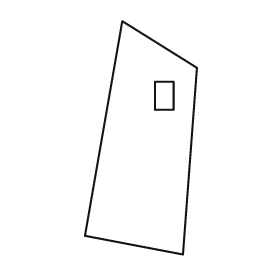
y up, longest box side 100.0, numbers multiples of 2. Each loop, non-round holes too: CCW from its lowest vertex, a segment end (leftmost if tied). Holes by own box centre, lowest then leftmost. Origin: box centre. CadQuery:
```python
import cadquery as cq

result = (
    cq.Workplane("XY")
    .moveTo(18.0, -50.0)
    .lineTo(24.0, 30.0)
    .lineTo(-8.0, 50.0)
    .lineTo(-24.0, -42.0)
    .close()
    .moveTo(6.0, 12.0)
    .lineTo(14.0, 12.0)
    .lineTo(14.0, 24.0)
    .lineTo(6.0, 24.0)
    .close()
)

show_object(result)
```